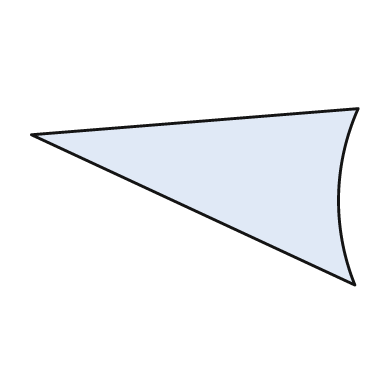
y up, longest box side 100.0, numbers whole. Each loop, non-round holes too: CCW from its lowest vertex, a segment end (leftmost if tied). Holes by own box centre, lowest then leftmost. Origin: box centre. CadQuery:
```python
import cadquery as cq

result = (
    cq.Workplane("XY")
    .moveTo(49.0, -27.0)
    .threePointArc((44.0, 0.0), (50.0, 27.0))
    .lineTo(-50.0, 19.0)
    .close()
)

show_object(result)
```